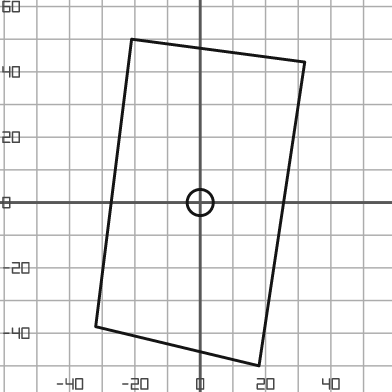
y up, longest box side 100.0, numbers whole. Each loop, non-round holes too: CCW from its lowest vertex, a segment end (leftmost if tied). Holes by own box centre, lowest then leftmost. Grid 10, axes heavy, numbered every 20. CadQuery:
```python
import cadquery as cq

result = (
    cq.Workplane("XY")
    .moveTo(18.0, -50.0)
    .lineTo(32.0, 43.0)
    .lineTo(-21.0, 50.0)
    .lineTo(-32.0, -38.0)
    .close()
    .moveTo(0.0, 0.0)
    .circle(4.0)
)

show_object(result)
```